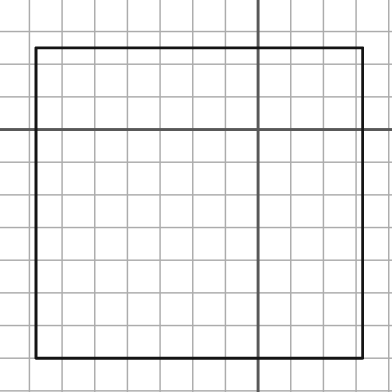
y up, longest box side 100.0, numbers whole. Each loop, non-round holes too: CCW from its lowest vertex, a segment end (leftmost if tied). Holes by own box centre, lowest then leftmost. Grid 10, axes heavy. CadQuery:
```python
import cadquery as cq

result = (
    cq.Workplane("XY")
    .moveTo(-68.0, -70.0)
    .lineTo(32.0, -70.0)
    .lineTo(32.0, 25.0)
    .lineTo(-68.0, 25.0)
    .close()
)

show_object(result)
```